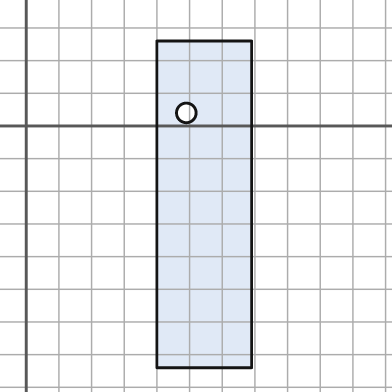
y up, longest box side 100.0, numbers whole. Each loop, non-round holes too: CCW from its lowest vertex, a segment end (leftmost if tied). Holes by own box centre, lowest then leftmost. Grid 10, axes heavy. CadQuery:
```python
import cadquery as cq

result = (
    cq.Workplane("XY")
    .moveTo(40.0, -74.0)
    .lineTo(69.0, -74.0)
    .lineTo(69.0, 26.0)
    .lineTo(40.0, 26.0)
    .close()
    .moveTo(49.0, 4.0)
    .circle(3.0)
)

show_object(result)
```